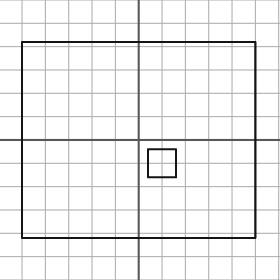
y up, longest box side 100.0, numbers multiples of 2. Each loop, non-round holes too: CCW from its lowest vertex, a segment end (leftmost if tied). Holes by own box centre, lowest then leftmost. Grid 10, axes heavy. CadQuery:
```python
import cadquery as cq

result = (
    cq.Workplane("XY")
    .moveTo(-50.0, -42.0)
    .lineTo(50.0, -42.0)
    .lineTo(50.0, 42.0)
    .lineTo(-50.0, 42.0)
    .close()
    .moveTo(4.0, -16.0)
    .lineTo(16.0, -16.0)
    .lineTo(16.0, -4.0)
    .lineTo(4.0, -4.0)
    .close()
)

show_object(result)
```